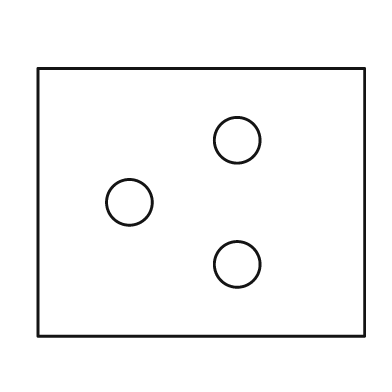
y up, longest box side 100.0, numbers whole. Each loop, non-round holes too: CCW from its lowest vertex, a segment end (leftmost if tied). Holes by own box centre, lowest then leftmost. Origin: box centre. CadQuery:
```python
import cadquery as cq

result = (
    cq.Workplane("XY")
    .moveTo(-50.0, -41.0)
    .lineTo(50.0, -41.0)
    .lineTo(50.0, 41.0)
    .lineTo(-50.0, 41.0)
    .close()
    .moveTo(11.0, -19.0)
    .circle(7.0)
    .moveTo(-22.0, 0.0)
    .circle(7.0)
    .moveTo(11.0, 19.0)
    .circle(7.0)
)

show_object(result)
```